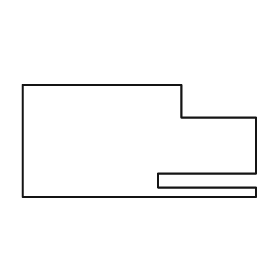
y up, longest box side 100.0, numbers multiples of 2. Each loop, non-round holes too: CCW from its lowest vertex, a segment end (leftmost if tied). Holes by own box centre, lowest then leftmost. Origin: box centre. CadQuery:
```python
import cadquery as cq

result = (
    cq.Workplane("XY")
    .moveTo(-50.0, -24.0)
    .lineTo(50.0, -24.0)
    .lineTo(50.0, -20.0)
    .lineTo(8.0, -20.0)
    .lineTo(8.0, -14.0)
    .lineTo(50.0, -14.0)
    .lineTo(50.0, 10.0)
    .lineTo(18.0, 10.0)
    .lineTo(18.0, 24.0)
    .lineTo(-50.0, 24.0)
    .close()
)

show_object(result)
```